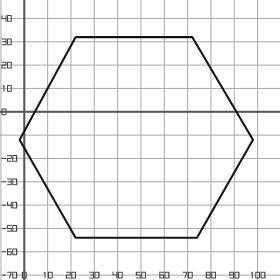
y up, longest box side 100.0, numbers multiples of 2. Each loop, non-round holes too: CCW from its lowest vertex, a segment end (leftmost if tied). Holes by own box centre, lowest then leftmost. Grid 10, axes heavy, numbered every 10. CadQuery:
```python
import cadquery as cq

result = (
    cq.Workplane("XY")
    .moveTo(22.0, -54.0)
    .lineTo(74.0, -54.0)
    .lineTo(98.0, -12.0)
    .lineTo(72.0, 32.0)
    .lineTo(22.0, 32.0)
    .lineTo(-2.0, -12.0)
    .close()
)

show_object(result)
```